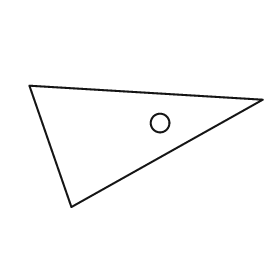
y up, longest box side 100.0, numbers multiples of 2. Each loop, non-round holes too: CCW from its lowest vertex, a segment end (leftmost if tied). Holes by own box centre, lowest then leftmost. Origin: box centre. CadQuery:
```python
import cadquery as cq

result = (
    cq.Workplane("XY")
    .moveTo(-32.0, -26.0)
    .lineTo(50.0, 20.0)
    .lineTo(-50.0, 26.0)
    .close()
    .moveTo(6.0, 10.0)
    .circle(4.0)
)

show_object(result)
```